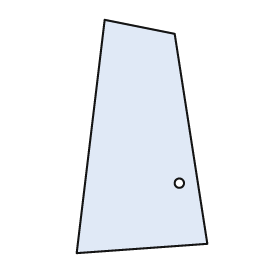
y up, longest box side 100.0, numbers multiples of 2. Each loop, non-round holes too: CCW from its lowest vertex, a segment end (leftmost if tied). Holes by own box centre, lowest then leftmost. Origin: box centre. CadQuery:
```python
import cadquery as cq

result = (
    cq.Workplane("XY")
    .moveTo(-28.0, -50.0)
    .lineTo(28.0, -46.0)
    .lineTo(14.0, 44.0)
    .lineTo(-16.0, 50.0)
    .close()
    .moveTo(16.0, -20.0)
    .circle(2.0)
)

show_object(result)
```